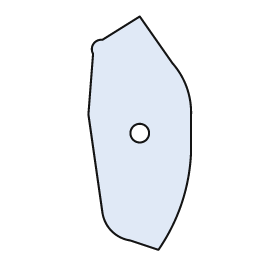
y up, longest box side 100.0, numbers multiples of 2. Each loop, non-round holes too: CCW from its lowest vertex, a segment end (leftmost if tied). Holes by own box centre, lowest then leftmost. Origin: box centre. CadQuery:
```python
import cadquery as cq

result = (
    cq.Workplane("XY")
    .moveTo(8.0, -50.0)
    .threePointArc((18.0, -30.0), (22.0, -8.0))
    .lineTo(22.0, 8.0)
    .threePointArc((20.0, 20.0), (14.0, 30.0))
    .lineTo(0.0, 50.0)
    .lineTo(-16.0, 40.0)
    .threePointArc((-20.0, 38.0), (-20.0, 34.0))
    .lineTo(-22.0, 8.0)
    .lineTo(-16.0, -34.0)
    .threePointArc((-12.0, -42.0), (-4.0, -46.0))
    .close()
    .moveTo(0.0, 0.0)
    .circle(4.0)
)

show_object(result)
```